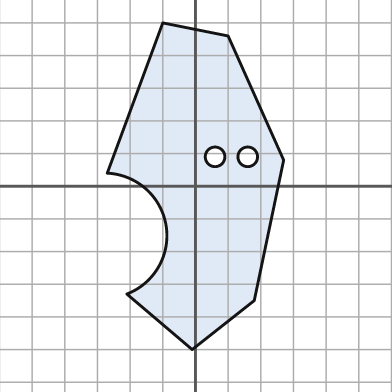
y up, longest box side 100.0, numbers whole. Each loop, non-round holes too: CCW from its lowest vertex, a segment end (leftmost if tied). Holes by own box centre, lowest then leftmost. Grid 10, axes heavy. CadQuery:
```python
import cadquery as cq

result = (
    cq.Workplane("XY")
    .moveTo(-1.0, -50.0)
    .lineTo(18.0, -35.0)
    .lineTo(27.0, 8.0)
    .lineTo(10.0, 46.0)
    .lineTo(-10.0, 50.0)
    .lineTo(-27.0, 4.0)
    .threePointArc((-9.0, -12.0), (-21.0, -33.0))
    .close()
    .moveTo(6.0, 9.0)
    .circle(3.0)
    .moveTo(16.0, 9.0)
    .circle(3.0)
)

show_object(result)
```